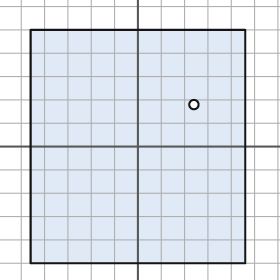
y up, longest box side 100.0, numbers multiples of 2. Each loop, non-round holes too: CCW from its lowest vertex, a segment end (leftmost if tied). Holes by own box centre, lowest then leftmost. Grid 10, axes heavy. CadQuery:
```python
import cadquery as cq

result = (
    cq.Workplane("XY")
    .moveTo(-46.0, -50.0)
    .lineTo(46.0, -50.0)
    .lineTo(46.0, 50.0)
    .lineTo(-46.0, 50.0)
    .close()
    .moveTo(24.0, 18.0)
    .circle(2.0)
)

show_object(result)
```